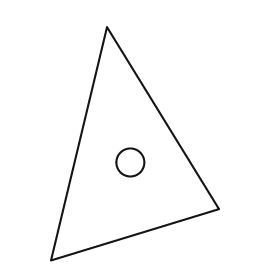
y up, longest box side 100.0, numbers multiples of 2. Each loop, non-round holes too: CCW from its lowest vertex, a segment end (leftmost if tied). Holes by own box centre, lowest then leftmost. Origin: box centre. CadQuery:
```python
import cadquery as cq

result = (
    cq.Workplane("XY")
    .moveTo(-36.0, -50.0)
    .lineTo(36.0, -28.0)
    .lineTo(-12.0, 50.0)
    .close()
    .moveTo(-2.0, -8.0)
    .circle(6.0)
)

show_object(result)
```